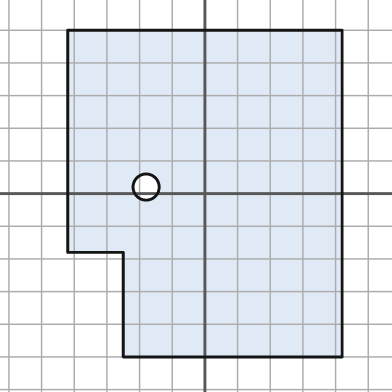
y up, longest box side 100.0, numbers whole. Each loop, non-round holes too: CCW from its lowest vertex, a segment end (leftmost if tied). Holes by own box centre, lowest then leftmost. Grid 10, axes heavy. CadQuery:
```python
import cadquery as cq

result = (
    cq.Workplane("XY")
    .moveTo(-25.0, -50.0)
    .lineTo(42.0, -50.0)
    .lineTo(42.0, 50.0)
    .lineTo(-42.0, 50.0)
    .lineTo(-42.0, -18.0)
    .lineTo(-25.0, -18.0)
    .close()
    .moveTo(-18.0, 2.0)
    .circle(4.0)
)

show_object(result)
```